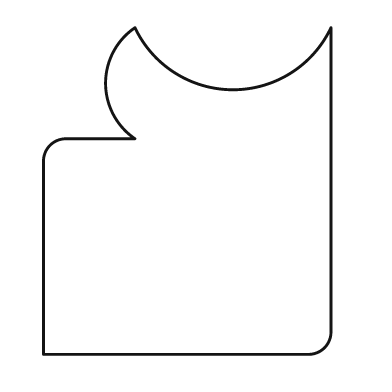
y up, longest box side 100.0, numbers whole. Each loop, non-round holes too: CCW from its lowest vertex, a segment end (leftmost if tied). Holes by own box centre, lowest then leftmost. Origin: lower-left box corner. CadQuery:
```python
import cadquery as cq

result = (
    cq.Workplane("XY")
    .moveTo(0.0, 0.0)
    .lineTo(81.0, 0.0)
    .threePointArc((86.0, 2.0), (88.0, 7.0))
    .lineTo(88.0, 100.0)
    .threePointArc((58.0, 81.0), (28.0, 100.0))
    .threePointArc((19.0, 83.0), (28.0, 66.0))
    .lineTo(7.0, 66.0)
    .threePointArc((2.0, 64.0), (0.0, 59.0))
    .close()
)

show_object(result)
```